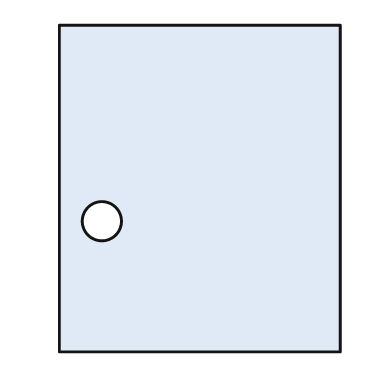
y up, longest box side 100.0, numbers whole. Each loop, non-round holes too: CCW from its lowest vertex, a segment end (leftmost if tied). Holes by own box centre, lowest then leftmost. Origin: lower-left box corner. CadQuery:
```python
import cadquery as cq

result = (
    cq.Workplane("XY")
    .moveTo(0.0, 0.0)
    .lineTo(86.0, 0.0)
    .lineTo(86.0, 100.0)
    .lineTo(0.0, 100.0)
    .close()
    .moveTo(13.0, 40.0)
    .circle(6.0)
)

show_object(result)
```